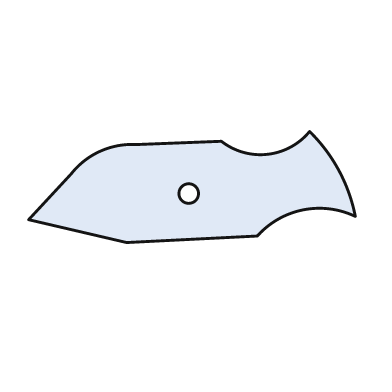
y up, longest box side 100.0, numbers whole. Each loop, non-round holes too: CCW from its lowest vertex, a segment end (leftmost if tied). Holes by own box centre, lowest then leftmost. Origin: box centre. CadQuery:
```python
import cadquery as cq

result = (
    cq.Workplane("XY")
    .moveTo(-20.0, -17.0)
    .lineTo(20.0, -15.0)
    .threePointArc((34.0, -7.0), (50.0, -9.0))
    .threePointArc((45.0, 5.0), (36.0, 17.0))
    .threePointArc((23.0, 10.0), (9.0, 14.0))
    .lineTo(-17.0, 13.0)
    .threePointArc((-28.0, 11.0), (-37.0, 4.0))
    .lineTo(-50.0, -10.0)
    .close()
    .moveTo(-1.0, -2.0)
    .circle(3.0)
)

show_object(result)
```